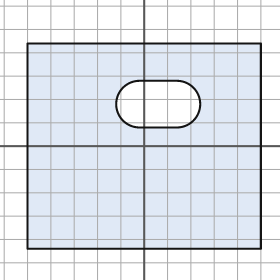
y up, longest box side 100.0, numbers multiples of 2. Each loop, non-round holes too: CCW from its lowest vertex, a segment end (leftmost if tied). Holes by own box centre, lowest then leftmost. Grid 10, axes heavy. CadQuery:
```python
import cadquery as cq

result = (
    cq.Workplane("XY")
    .moveTo(-50.0, -44.0)
    .lineTo(50.0, -44.0)
    .lineTo(50.0, 44.0)
    .lineTo(-50.0, 44.0)
    .close()
    .moveTo(-2.0, 8.0)
    .lineTo(14.0, 8.0)
    .threePointArc((24.0, 18.0), (14.0, 28.0))
    .lineTo(-2.0, 28.0)
    .threePointArc((-12.0, 18.0), (-2.0, 8.0))
    .close()
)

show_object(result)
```